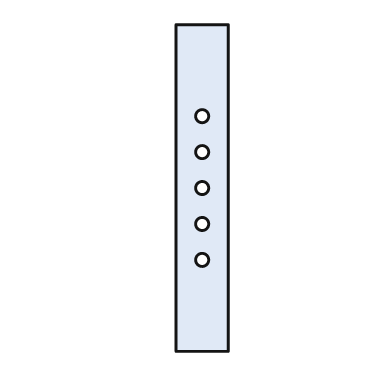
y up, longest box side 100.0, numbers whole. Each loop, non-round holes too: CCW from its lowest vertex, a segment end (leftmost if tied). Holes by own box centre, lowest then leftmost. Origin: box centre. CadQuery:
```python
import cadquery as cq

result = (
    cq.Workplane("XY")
    .moveTo(-8.0, -50.0)
    .lineTo(8.0, -50.0)
    .lineTo(8.0, 50.0)
    .lineTo(-8.0, 50.0)
    .close()
    .moveTo(0.0, -22.0)
    .circle(2.0)
    .moveTo(0.0, -11.0)
    .circle(2.0)
    .moveTo(0.0, 0.0)
    .circle(2.0)
    .moveTo(0.0, 11.0)
    .circle(2.0)
    .moveTo(0.0, 22.0)
    .circle(2.0)
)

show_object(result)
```